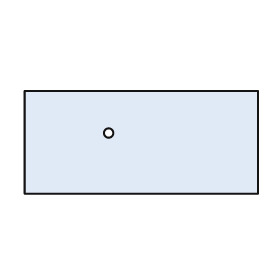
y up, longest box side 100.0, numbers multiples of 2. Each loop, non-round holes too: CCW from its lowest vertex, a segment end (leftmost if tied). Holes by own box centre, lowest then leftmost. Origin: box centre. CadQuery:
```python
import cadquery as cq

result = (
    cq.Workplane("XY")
    .moveTo(-50.0, -22.0)
    .lineTo(50.0, -22.0)
    .lineTo(50.0, 22.0)
    .lineTo(-50.0, 22.0)
    .close()
    .moveTo(-14.0, 4.0)
    .circle(2.0)
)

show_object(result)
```